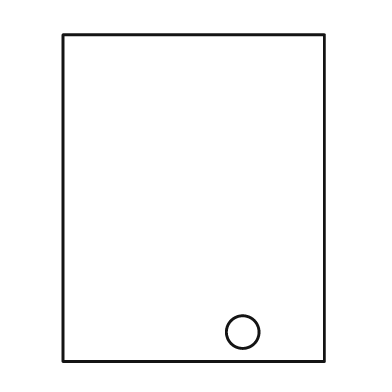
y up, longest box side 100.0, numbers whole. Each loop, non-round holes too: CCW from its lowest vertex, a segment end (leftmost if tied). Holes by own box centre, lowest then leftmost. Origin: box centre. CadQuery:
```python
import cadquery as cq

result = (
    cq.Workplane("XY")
    .moveTo(-40.0, -50.0)
    .lineTo(40.0, -50.0)
    .lineTo(40.0, 50.0)
    .lineTo(-40.0, 50.0)
    .close()
    .moveTo(15.0, -41.0)
    .circle(5.0)
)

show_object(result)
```